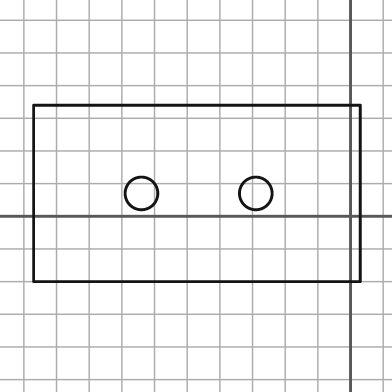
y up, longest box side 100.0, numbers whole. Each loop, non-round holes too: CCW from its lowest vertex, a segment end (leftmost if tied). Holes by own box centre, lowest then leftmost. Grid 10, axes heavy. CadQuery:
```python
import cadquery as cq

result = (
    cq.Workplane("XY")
    .moveTo(-97.0, -20.0)
    .lineTo(3.0, -20.0)
    .lineTo(3.0, 34.0)
    .lineTo(-97.0, 34.0)
    .close()
    .moveTo(-64.0, 7.0)
    .circle(5.0)
    .moveTo(-29.0, 7.0)
    .circle(5.0)
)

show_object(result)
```